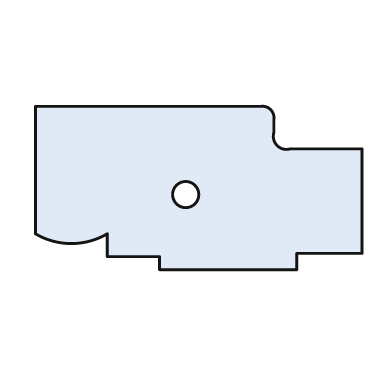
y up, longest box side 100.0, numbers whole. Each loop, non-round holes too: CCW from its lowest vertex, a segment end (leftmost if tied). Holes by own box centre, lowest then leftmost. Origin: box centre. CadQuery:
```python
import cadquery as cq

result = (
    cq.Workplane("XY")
    .moveTo(-12.0, -25.0)
    .lineTo(30.0, -25.0)
    .lineTo(30.0, -20.0)
    .lineTo(50.0, -20.0)
    .lineTo(50.0, 12.0)
    .lineTo(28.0, 12.0)
    .threePointArc((24.0, 13.0), (23.0, 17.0))
    .lineTo(23.0, 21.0)
    .threePointArc((22.0, 24.0), (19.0, 25.0))
    .lineTo(-50.0, 25.0)
    .lineTo(-50.0, -14.0)
    .threePointArc((-39.0, -17.0), (-28.0, -14.0))
    .lineTo(-28.0, -21.0)
    .lineTo(-12.0, -21.0)
    .close()
    .moveTo(-4.0, -2.0)
    .circle(4.0)
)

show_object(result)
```